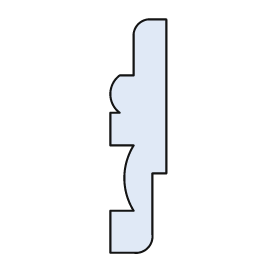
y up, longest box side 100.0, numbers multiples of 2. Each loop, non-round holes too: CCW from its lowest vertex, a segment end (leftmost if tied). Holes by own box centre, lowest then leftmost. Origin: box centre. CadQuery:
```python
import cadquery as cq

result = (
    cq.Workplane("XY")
    .moveTo(-12.0, -50.0)
    .lineTo(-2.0, -50.0)
    .threePointArc((4.0, -48.0), (6.0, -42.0))
    .lineTo(6.0, -16.0)
    .lineTo(12.0, -16.0)
    .lineTo(12.0, 50.0)
    .lineTo(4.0, 50.0)
    .threePointArc((0.0, 48.0), (-2.0, 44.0))
    .lineTo(-2.0, 26.0)
    .lineTo(-8.0, 26.0)
    .threePointArc((-12.0, 18.0), (-8.0, 10.0))
    .lineTo(-12.0, 10.0)
    .lineTo(-12.0, -4.0)
    .lineTo(-2.0, -4.0)
    .threePointArc((-6.0, -18.0), (-2.0, -32.0))
    .lineTo(-12.0, -32.0)
    .close()
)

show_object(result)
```